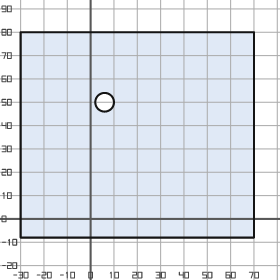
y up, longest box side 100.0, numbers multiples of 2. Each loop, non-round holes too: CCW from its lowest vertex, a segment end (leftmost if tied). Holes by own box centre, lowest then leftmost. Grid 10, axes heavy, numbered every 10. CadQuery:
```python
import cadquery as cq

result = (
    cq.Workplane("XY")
    .moveTo(-30.0, -8.0)
    .lineTo(70.0, -8.0)
    .lineTo(70.0, 80.0)
    .lineTo(-30.0, 80.0)
    .close()
    .moveTo(6.0, 50.0)
    .circle(4.0)
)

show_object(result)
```